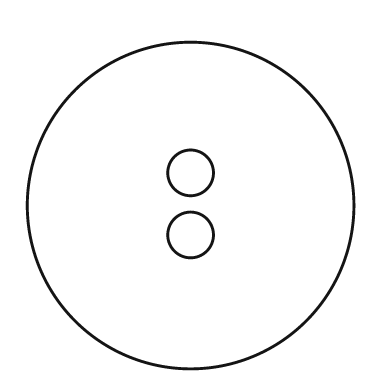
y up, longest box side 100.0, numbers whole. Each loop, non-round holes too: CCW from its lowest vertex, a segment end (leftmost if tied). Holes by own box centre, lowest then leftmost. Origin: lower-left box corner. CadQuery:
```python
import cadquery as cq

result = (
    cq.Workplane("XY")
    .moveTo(50.0, 50.0)
    .circle(50.0)
    .moveTo(50.0, 41.0)
    .circle(7.0)
    .moveTo(50.0, 60.0)
    .circle(7.0)
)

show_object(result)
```